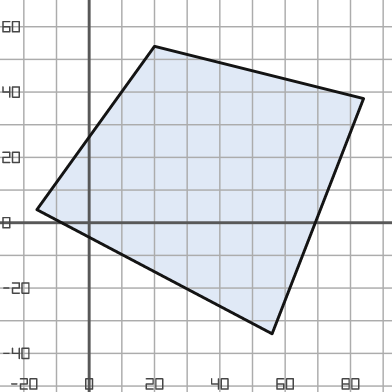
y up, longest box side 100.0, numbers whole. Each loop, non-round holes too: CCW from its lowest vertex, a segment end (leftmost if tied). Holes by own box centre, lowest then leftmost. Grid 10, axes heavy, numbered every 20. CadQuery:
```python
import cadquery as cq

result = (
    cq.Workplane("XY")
    .moveTo(56.0, -34.0)
    .lineTo(84.0, 38.0)
    .lineTo(20.0, 54.0)
    .lineTo(-16.0, 4.0)
    .close()
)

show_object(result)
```